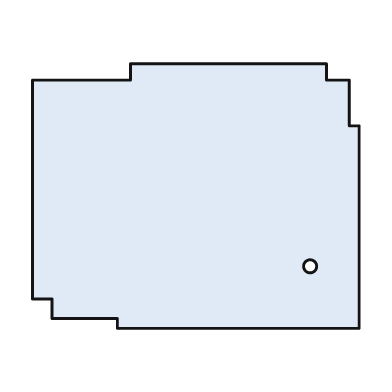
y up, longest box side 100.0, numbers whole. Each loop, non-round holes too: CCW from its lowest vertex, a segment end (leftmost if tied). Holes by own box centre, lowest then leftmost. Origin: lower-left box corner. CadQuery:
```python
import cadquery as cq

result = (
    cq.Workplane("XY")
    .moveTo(26.0, 0.0)
    .lineTo(100.0, 0.0)
    .lineTo(100.0, 62.0)
    .lineTo(97.0, 62.0)
    .lineTo(97.0, 76.0)
    .lineTo(90.0, 76.0)
    .lineTo(90.0, 81.0)
    .lineTo(30.0, 81.0)
    .lineTo(30.0, 76.0)
    .lineTo(0.0, 76.0)
    .lineTo(0.0, 9.0)
    .lineTo(6.0, 9.0)
    .lineTo(6.0, 3.0)
    .lineTo(26.0, 3.0)
    .close()
    .moveTo(85.0, 19.0)
    .circle(2.0)
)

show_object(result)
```